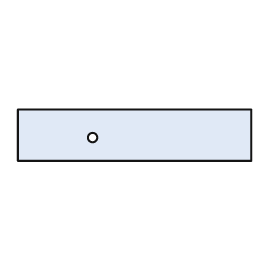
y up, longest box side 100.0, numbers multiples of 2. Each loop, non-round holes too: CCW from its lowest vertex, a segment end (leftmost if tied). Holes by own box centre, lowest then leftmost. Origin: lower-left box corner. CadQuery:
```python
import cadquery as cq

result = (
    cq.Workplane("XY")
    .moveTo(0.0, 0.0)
    .lineTo(100.0, 0.0)
    .lineTo(100.0, 22.0)
    .lineTo(0.0, 22.0)
    .close()
    .moveTo(32.0, 10.0)
    .circle(2.0)
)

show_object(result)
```